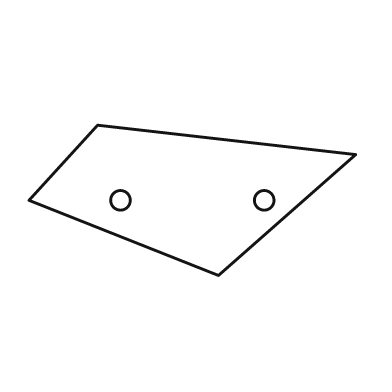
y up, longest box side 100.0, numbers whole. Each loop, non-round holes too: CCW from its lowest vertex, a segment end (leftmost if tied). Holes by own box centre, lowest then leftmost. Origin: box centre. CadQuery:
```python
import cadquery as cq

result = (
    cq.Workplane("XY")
    .moveTo(8.0, -23.0)
    .lineTo(50.0, 14.0)
    .lineTo(-29.0, 23.0)
    .lineTo(-50.0, 0.0)
    .close()
    .moveTo(-22.0, 0.0)
    .circle(3.0)
    .moveTo(22.0, 0.0)
    .circle(3.0)
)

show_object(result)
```